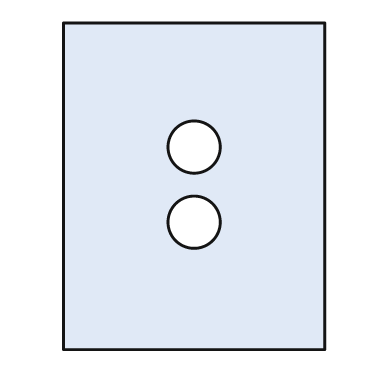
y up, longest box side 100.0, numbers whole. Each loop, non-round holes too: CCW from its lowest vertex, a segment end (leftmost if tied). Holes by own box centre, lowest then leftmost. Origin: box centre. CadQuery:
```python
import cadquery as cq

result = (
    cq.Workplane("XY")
    .moveTo(-40.0, -50.0)
    .lineTo(40.0, -50.0)
    .lineTo(40.0, 50.0)
    .lineTo(-40.0, 50.0)
    .close()
    .moveTo(0.0, -11.0)
    .circle(8.0)
    .moveTo(0.0, 12.0)
    .circle(8.0)
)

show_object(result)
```